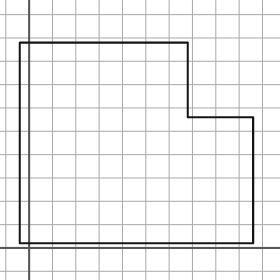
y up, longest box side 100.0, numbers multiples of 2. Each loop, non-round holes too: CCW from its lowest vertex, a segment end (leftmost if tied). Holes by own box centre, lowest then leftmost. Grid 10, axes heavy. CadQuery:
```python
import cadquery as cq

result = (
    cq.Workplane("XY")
    .moveTo(-4.0, 2.0)
    .lineTo(96.0, 2.0)
    .lineTo(96.0, 56.0)
    .lineTo(68.0, 56.0)
    .lineTo(68.0, 88.0)
    .lineTo(-4.0, 88.0)
    .close()
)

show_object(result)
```